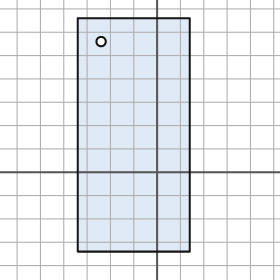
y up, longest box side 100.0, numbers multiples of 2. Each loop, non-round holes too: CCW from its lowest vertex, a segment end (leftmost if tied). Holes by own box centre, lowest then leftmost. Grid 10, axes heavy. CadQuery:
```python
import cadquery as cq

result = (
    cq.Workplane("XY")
    .moveTo(-34.0, -34.0)
    .lineTo(14.0, -34.0)
    .lineTo(14.0, 66.0)
    .lineTo(-34.0, 66.0)
    .close()
    .moveTo(-24.0, 56.0)
    .circle(2.0)
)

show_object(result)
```